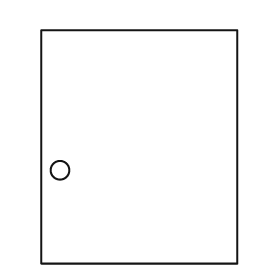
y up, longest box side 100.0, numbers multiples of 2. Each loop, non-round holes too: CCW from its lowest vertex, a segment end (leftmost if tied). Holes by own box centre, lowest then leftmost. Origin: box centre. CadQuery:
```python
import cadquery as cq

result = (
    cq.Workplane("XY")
    .moveTo(-42.0, -50.0)
    .lineTo(42.0, -50.0)
    .lineTo(42.0, 50.0)
    .lineTo(-42.0, 50.0)
    .close()
    .moveTo(-34.0, -10.0)
    .circle(4.0)
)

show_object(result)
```